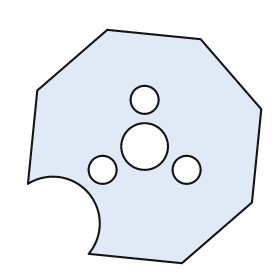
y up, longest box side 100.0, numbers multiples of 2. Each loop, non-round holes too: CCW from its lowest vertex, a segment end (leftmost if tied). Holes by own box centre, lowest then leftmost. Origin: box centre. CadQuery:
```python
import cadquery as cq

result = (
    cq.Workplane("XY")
    .moveTo(16.0, -50.0)
    .lineTo(46.0, -24.0)
    .lineTo(50.0, 16.0)
    .lineTo(24.0, 46.0)
    .lineTo(-16.0, 50.0)
    .lineTo(-46.0, 24.0)
    .lineTo(-50.0, -16.0)
    .threePointArc((-24.0, -20.0), (-24.0, -46.0))
    .close()
    .moveTo(-18.0, -10.0)
    .circle(6.0)
    .moveTo(18.0, -10.0)
    .circle(6.0)
    .moveTo(0.0, 0.0)
    .circle(10.0)
    .moveTo(0.0, 20.0)
    .circle(6.0)
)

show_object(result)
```